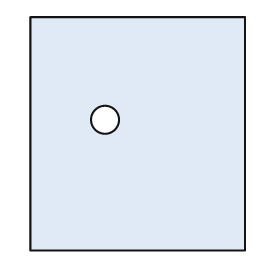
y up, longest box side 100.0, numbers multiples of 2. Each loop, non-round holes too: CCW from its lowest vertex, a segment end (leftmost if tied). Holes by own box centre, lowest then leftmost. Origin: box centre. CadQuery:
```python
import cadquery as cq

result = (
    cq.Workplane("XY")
    .moveTo(-46.0, -50.0)
    .lineTo(46.0, -50.0)
    .lineTo(46.0, 50.0)
    .lineTo(-46.0, 50.0)
    .close()
    .moveTo(-14.0, 6.0)
    .circle(6.0)
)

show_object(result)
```